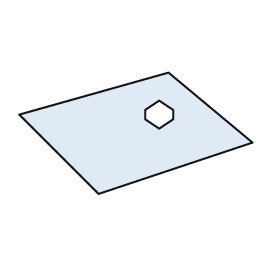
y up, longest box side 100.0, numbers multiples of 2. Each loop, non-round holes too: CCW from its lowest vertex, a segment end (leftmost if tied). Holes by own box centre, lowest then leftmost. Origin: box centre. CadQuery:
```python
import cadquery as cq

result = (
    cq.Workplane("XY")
    .moveTo(-16.0, -26.0)
    .lineTo(50.0, -4.0)
    .lineTo(14.0, 26.0)
    .lineTo(-50.0, 8.0)
    .close()
    .moveTo(10.0, 2.0)
    .lineTo(16.0, 6.0)
    .lineTo(16.0, 10.0)
    .lineTo(10.0, 14.0)
    .lineTo(4.0, 10.0)
    .lineTo(4.0, 6.0)
    .close()
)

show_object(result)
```